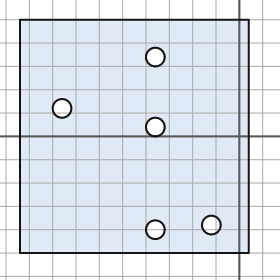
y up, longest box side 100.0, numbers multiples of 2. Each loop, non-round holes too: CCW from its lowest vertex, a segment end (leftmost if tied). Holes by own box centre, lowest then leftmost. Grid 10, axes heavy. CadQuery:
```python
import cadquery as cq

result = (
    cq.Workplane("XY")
    .moveTo(-94.0, -50.0)
    .lineTo(4.0, -50.0)
    .lineTo(4.0, 50.0)
    .lineTo(-94.0, 50.0)
    .close()
    .moveTo(-36.0, -40.0)
    .circle(4.0)
    .moveTo(-12.0, -38.0)
    .circle(4.0)
    .moveTo(-36.0, 4.0)
    .circle(4.0)
    .moveTo(-76.0, 12.0)
    .circle(4.0)
    .moveTo(-36.0, 34.0)
    .circle(4.0)
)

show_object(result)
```